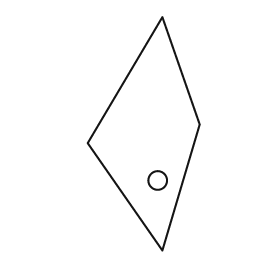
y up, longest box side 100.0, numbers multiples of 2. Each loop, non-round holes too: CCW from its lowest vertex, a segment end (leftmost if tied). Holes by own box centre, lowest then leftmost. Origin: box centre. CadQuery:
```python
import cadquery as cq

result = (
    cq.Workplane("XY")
    .moveTo(8.0, -50.0)
    .lineTo(24.0, 4.0)
    .lineTo(8.0, 50.0)
    .lineTo(-24.0, -4.0)
    .close()
    .moveTo(6.0, -20.0)
    .circle(4.0)
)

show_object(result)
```